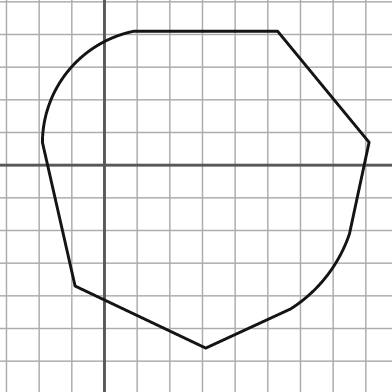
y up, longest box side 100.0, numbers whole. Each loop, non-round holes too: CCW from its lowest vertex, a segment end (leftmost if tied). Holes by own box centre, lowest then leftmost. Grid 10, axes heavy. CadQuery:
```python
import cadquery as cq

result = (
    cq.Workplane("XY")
    .moveTo(31.0, -56.0)
    .lineTo(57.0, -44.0)
    .threePointArc((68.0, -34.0), (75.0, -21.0))
    .lineTo(81.0, 7.0)
    .lineTo(53.0, 41.0)
    .lineTo(9.0, 41.0)
    .threePointArc((-11.0, 29.0), (-19.0, 7.0))
    .lineTo(-9.0, -37.0)
    .close()
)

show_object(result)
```